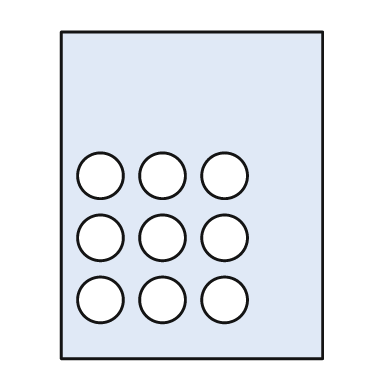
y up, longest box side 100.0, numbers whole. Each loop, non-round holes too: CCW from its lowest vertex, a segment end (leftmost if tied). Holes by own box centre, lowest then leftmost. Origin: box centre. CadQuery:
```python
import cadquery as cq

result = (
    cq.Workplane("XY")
    .moveTo(-40.0, -50.0)
    .lineTo(40.0, -50.0)
    .lineTo(40.0, 50.0)
    .lineTo(-40.0, 50.0)
    .close()
    .moveTo(-28.0, -32.0)
    .circle(7.0)
    .moveTo(-9.0, -32.0)
    .circle(7.0)
    .moveTo(10.0, -32.0)
    .circle(7.0)
    .moveTo(-28.0, -13.0)
    .circle(7.0)
    .moveTo(-9.0, -13.0)
    .circle(7.0)
    .moveTo(10.0, -13.0)
    .circle(7.0)
    .moveTo(-28.0, 6.0)
    .circle(7.0)
    .moveTo(-9.0, 6.0)
    .circle(7.0)
    .moveTo(10.0, 6.0)
    .circle(7.0)
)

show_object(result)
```